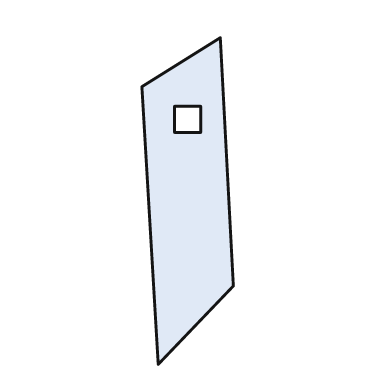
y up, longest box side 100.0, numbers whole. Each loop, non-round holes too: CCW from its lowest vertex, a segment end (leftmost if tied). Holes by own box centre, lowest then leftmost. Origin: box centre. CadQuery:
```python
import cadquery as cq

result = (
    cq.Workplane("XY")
    .moveTo(-9.0, -50.0)
    .lineTo(14.0, -26.0)
    .lineTo(10.0, 50.0)
    .lineTo(-14.0, 35.0)
    .close()
    .moveTo(-4.0, 21.0)
    .lineTo(4.0, 21.0)
    .lineTo(4.0, 29.0)
    .lineTo(-4.0, 29.0)
    .close()
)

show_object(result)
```